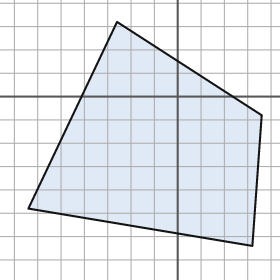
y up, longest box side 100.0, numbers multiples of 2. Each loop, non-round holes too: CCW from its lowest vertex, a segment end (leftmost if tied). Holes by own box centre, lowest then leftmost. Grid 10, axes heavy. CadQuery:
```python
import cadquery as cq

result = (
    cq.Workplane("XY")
    .moveTo(32.0, -64.0)
    .lineTo(36.0, -8.0)
    .lineTo(-26.0, 32.0)
    .lineTo(-64.0, -48.0)
    .close()
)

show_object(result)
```